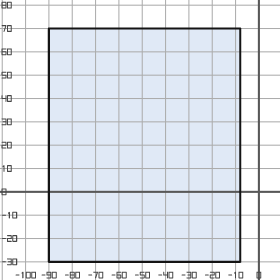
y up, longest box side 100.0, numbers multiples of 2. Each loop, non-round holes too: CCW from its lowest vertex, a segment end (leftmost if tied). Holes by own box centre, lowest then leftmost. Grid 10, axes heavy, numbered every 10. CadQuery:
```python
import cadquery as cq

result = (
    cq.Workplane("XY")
    .moveTo(-90.0, -30.0)
    .lineTo(-8.0, -30.0)
    .lineTo(-8.0, 70.0)
    .lineTo(-90.0, 70.0)
    .close()
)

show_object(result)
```